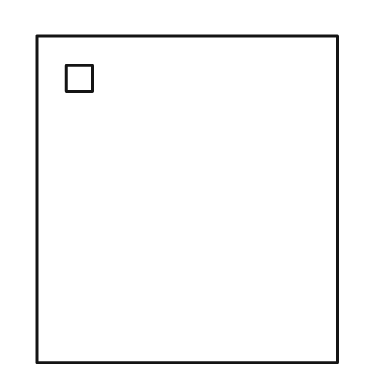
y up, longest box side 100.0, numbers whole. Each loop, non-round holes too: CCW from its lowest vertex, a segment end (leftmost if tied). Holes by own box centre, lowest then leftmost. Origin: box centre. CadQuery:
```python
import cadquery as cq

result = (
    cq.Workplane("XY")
    .moveTo(-46.0, -50.0)
    .lineTo(46.0, -50.0)
    .lineTo(46.0, 50.0)
    .lineTo(-46.0, 50.0)
    .close()
    .moveTo(-37.0, 33.0)
    .lineTo(-29.0, 33.0)
    .lineTo(-29.0, 41.0)
    .lineTo(-37.0, 41.0)
    .close()
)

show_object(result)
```